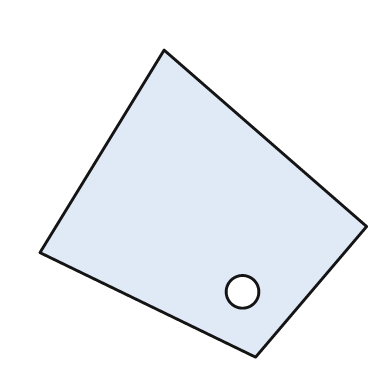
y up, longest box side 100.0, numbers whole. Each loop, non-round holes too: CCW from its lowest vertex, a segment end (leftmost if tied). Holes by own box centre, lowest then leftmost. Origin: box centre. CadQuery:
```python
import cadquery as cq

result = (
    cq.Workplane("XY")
    .moveTo(16.0, -47.0)
    .lineTo(50.0, -7.0)
    .lineTo(-12.0, 47.0)
    .lineTo(-50.0, -15.0)
    .close()
    .moveTo(12.0, -27.0)
    .circle(5.0)
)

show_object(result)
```